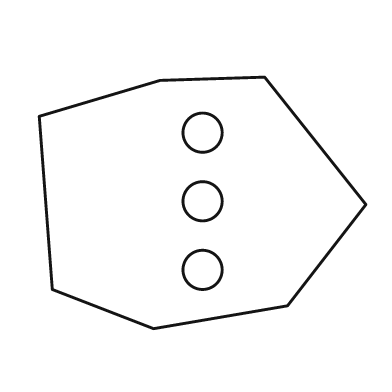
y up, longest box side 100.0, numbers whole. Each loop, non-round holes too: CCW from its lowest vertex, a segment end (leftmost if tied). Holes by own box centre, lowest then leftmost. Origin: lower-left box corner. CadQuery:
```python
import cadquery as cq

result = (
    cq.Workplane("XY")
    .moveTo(35.0, 0.0)
    .lineTo(76.0, 7.0)
    .lineTo(100.0, 38.0)
    .lineTo(69.0, 77.0)
    .lineTo(37.0, 76.0)
    .lineTo(0.0, 65.0)
    .lineTo(4.0, 12.0)
    .close()
    .moveTo(50.0, 18.0)
    .circle(6.0)
    .moveTo(50.0, 39.0)
    .circle(6.0)
    .moveTo(50.0, 60.0)
    .circle(6.0)
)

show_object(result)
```